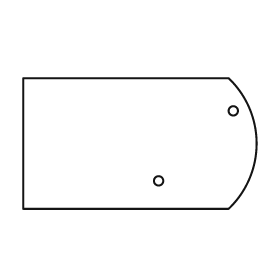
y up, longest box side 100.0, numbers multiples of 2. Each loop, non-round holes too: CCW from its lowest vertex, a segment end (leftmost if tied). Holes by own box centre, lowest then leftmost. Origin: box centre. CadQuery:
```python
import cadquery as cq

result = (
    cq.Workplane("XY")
    .moveTo(-50.0, -28.0)
    .lineTo(38.0, -28.0)
    .threePointArc((50.0, 0.0), (38.0, 28.0))
    .lineTo(-50.0, 28.0)
    .close()
    .moveTo(8.0, -16.0)
    .circle(2.0)
    .moveTo(40.0, 14.0)
    .circle(2.0)
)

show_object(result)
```